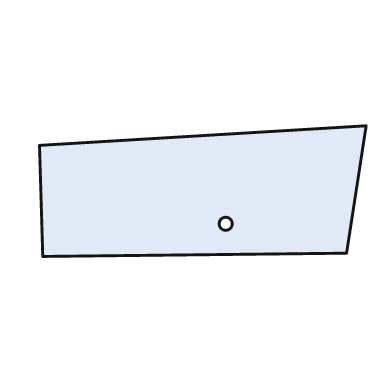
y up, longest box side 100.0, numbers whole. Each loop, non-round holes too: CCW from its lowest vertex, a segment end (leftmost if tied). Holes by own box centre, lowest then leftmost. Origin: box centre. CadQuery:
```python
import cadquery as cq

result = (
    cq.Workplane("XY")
    .moveTo(-49.0, -20.0)
    .lineTo(44.0, -19.0)
    .lineTo(50.0, 20.0)
    .lineTo(-50.0, 14.0)
    .close()
    .moveTo(7.0, -10.0)
    .circle(2.0)
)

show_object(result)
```